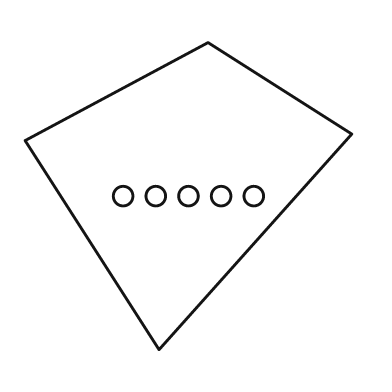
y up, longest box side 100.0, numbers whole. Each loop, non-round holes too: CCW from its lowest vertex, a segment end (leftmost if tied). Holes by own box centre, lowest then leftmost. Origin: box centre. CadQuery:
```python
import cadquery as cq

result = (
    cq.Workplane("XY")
    .moveTo(-9.0, -47.0)
    .lineTo(50.0, 19.0)
    .lineTo(6.0, 47.0)
    .lineTo(-50.0, 17.0)
    .close()
    .moveTo(-20.0, 0.0)
    .circle(3.0)
    .moveTo(-10.0, 0.0)
    .circle(3.0)
    .moveTo(0.0, 0.0)
    .circle(3.0)
    .moveTo(10.0, 0.0)
    .circle(3.0)
    .moveTo(20.0, 0.0)
    .circle(3.0)
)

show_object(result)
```